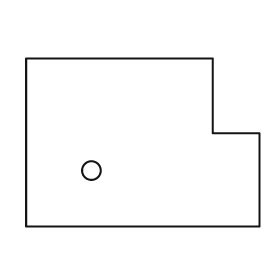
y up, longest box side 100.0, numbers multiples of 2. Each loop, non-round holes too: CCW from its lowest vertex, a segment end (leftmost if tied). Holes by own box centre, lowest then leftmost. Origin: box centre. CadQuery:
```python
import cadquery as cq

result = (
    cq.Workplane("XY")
    .moveTo(-50.0, -36.0)
    .lineTo(50.0, -36.0)
    .lineTo(50.0, 4.0)
    .lineTo(30.0, 4.0)
    .lineTo(30.0, 36.0)
    .lineTo(-50.0, 36.0)
    .close()
    .moveTo(-22.0, -12.0)
    .circle(4.0)
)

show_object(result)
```